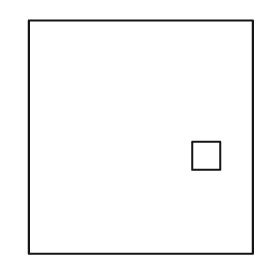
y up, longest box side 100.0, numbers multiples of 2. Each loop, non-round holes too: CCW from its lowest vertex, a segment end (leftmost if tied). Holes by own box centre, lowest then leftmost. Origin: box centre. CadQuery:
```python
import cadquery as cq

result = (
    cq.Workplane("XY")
    .moveTo(-48.0, -50.0)
    .lineTo(48.0, -50.0)
    .lineTo(48.0, 50.0)
    .lineTo(-48.0, 50.0)
    .close()
    .moveTo(22.0, -14.0)
    .lineTo(34.0, -14.0)
    .lineTo(34.0, -2.0)
    .lineTo(22.0, -2.0)
    .close()
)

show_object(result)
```